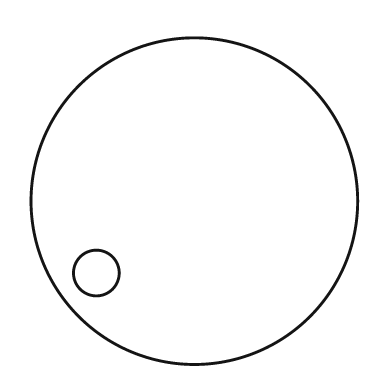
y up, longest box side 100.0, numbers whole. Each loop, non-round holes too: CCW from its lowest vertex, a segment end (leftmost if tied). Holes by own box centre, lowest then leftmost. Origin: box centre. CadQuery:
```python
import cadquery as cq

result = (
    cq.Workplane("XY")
    .moveTo(0.0, 0.0)
    .circle(50.0)
    .moveTo(-30.0, -22.0)
    .circle(7.0)
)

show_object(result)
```